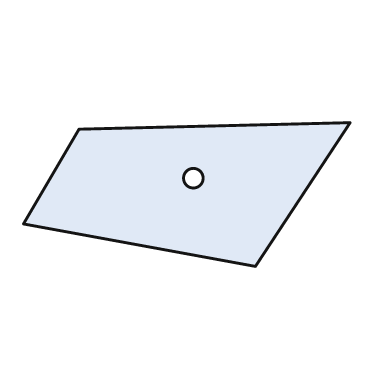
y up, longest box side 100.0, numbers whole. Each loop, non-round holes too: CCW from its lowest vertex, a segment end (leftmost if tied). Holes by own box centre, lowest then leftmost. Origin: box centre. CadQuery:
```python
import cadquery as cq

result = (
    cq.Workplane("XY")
    .moveTo(21.0, -22.0)
    .lineTo(50.0, 22.0)
    .lineTo(-33.0, 20.0)
    .lineTo(-50.0, -9.0)
    .close()
    .moveTo(2.0, 5.0)
    .circle(3.0)
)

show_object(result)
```